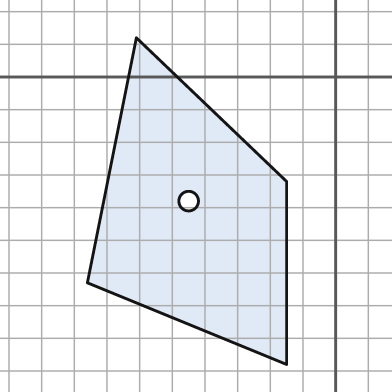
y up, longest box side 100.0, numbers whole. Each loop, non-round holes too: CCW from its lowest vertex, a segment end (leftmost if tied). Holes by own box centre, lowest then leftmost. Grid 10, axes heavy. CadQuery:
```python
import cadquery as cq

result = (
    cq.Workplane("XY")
    .moveTo(-15.0, -88.0)
    .lineTo(-15.0, -32.0)
    .lineTo(-61.0, 12.0)
    .lineTo(-76.0, -63.0)
    .close()
    .moveTo(-45.0, -38.0)
    .circle(3.0)
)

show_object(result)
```